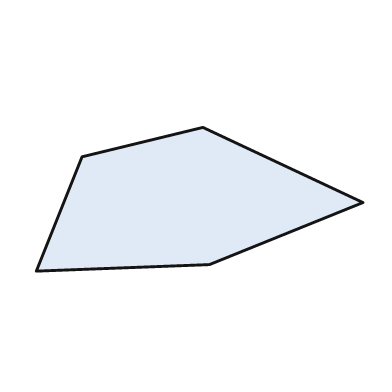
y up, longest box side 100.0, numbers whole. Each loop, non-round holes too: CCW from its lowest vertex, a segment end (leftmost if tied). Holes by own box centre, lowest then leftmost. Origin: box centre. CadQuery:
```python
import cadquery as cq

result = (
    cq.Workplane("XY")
    .moveTo(-50.0, -22.0)
    .lineTo(3.0, -20.0)
    .lineTo(50.0, -1.0)
    .lineTo(1.0, 22.0)
    .lineTo(-36.0, 13.0)
    .close()
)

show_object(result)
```